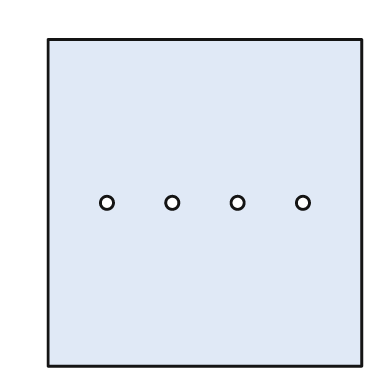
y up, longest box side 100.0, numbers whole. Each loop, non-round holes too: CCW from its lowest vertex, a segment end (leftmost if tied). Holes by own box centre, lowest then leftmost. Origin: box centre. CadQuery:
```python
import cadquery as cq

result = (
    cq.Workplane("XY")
    .moveTo(-48.0, -50.0)
    .lineTo(48.0, -50.0)
    .lineTo(48.0, 50.0)
    .lineTo(-48.0, 50.0)
    .close()
    .moveTo(-30.0, 0.0)
    .circle(2.0)
    .moveTo(-10.0, 0.0)
    .circle(2.0)
    .moveTo(10.0, 0.0)
    .circle(2.0)
    .moveTo(30.0, 0.0)
    .circle(2.0)
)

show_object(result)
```